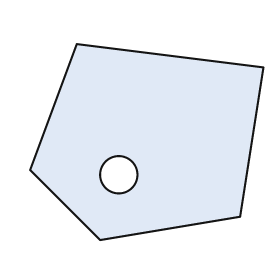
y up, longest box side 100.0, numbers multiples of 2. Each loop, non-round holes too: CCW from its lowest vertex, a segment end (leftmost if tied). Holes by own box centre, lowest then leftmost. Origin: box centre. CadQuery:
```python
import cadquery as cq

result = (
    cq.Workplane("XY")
    .moveTo(-20.0, -42.0)
    .lineTo(40.0, -32.0)
    .lineTo(50.0, 32.0)
    .lineTo(-30.0, 42.0)
    .lineTo(-50.0, -12.0)
    .close()
    .moveTo(-12.0, -14.0)
    .circle(8.0)
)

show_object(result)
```